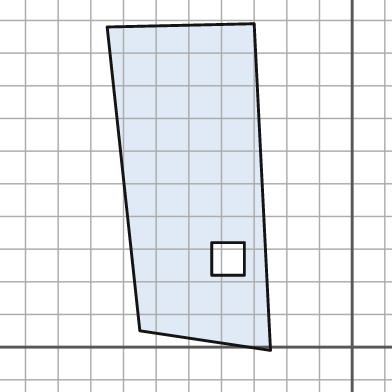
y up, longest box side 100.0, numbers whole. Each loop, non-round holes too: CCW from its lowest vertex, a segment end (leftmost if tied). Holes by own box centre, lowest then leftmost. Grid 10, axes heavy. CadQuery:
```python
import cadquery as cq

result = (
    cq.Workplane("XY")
    .moveTo(-25.0, -1.0)
    .lineTo(-30.0, 99.0)
    .lineTo(-75.0, 98.0)
    .lineTo(-65.0, 5.0)
    .close()
    .moveTo(-43.0, 22.0)
    .lineTo(-33.0, 22.0)
    .lineTo(-33.0, 32.0)
    .lineTo(-43.0, 32.0)
    .close()
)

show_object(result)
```